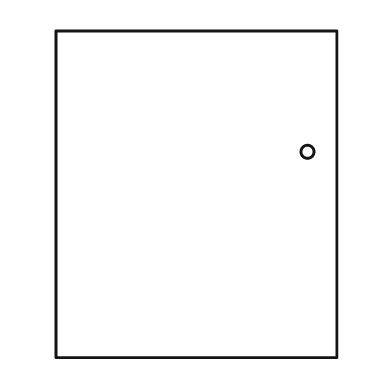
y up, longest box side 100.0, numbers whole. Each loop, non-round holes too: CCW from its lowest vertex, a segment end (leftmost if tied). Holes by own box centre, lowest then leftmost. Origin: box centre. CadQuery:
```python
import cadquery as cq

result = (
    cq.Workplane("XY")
    .moveTo(-43.0, -50.0)
    .lineTo(43.0, -50.0)
    .lineTo(43.0, 50.0)
    .lineTo(-43.0, 50.0)
    .close()
    .moveTo(34.0, 13.0)
    .circle(2.0)
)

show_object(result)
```